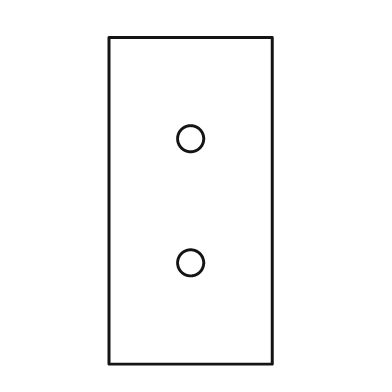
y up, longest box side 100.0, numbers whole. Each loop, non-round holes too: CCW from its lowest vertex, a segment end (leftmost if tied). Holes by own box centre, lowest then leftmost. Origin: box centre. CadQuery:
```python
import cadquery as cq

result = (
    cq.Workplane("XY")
    .moveTo(-25.0, -50.0)
    .lineTo(25.0, -50.0)
    .lineTo(25.0, 50.0)
    .lineTo(-25.0, 50.0)
    .close()
    .moveTo(0.0, -19.0)
    .circle(4.0)
    .moveTo(0.0, 19.0)
    .circle(4.0)
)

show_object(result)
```